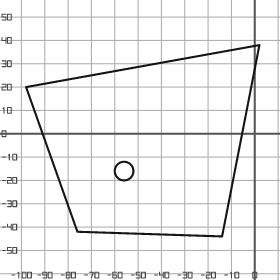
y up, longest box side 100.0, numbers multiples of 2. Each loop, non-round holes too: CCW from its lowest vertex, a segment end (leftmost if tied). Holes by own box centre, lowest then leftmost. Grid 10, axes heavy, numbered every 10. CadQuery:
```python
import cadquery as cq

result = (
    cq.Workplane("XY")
    .moveTo(-14.0, -44.0)
    .lineTo(2.0, 38.0)
    .lineTo(-98.0, 20.0)
    .lineTo(-76.0, -42.0)
    .close()
    .moveTo(-56.0, -16.0)
    .circle(4.0)
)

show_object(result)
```